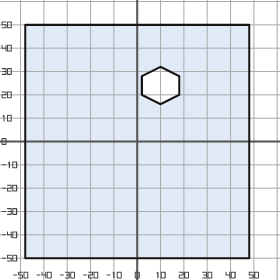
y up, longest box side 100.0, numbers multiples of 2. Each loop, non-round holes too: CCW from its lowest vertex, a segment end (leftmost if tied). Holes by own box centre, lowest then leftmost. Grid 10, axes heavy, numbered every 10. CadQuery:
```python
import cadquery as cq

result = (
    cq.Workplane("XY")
    .moveTo(-48.0, -50.0)
    .lineTo(48.0, -50.0)
    .lineTo(48.0, 50.0)
    .lineTo(-48.0, 50.0)
    .close()
    .moveTo(10.0, 16.0)
    .lineTo(18.0, 20.0)
    .lineTo(18.0, 28.0)
    .lineTo(10.0, 32.0)
    .lineTo(2.0, 28.0)
    .lineTo(2.0, 20.0)
    .close()
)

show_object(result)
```